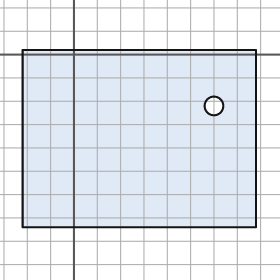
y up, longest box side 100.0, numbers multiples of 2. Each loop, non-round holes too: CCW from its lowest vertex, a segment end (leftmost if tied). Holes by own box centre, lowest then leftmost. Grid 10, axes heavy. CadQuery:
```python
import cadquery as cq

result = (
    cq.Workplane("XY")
    .moveTo(-22.0, -74.0)
    .lineTo(78.0, -74.0)
    .lineTo(78.0, 2.0)
    .lineTo(-22.0, 2.0)
    .close()
    .moveTo(60.0, -22.0)
    .circle(4.0)
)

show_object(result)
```